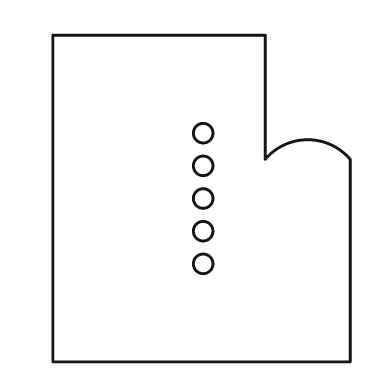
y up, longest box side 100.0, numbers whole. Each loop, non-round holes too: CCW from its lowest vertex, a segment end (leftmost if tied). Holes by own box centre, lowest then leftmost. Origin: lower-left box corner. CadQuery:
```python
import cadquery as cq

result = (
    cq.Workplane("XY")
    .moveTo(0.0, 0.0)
    .lineTo(91.0, 0.0)
    .lineTo(91.0, 62.0)
    .threePointArc((78.0, 68.0), (65.0, 62.0))
    .lineTo(65.0, 100.0)
    .lineTo(0.0, 100.0)
    .close()
    .moveTo(46.0, 30.0)
    .circle(3.0)
    .moveTo(46.0, 40.0)
    .circle(3.0)
    .moveTo(46.0, 50.0)
    .circle(3.0)
    .moveTo(46.0, 60.0)
    .circle(3.0)
    .moveTo(46.0, 70.0)
    .circle(3.0)
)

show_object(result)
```